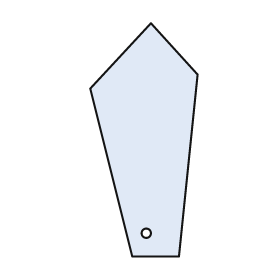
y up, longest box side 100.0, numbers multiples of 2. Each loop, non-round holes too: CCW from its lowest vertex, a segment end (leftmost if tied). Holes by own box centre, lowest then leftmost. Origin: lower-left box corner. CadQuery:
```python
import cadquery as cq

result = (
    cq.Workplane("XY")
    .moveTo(18.0, 0.0)
    .lineTo(38.0, 0.0)
    .lineTo(46.0, 78.0)
    .lineTo(26.0, 100.0)
    .lineTo(0.0, 72.0)
    .close()
    .moveTo(24.0, 10.0)
    .circle(2.0)
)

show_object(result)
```